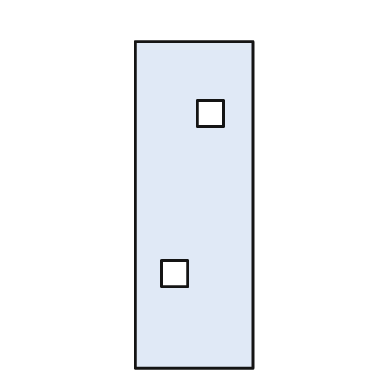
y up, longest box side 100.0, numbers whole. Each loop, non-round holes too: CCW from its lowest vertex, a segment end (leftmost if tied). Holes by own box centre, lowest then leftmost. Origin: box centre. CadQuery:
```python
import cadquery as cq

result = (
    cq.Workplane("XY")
    .moveTo(-18.0, -50.0)
    .lineTo(18.0, -50.0)
    .lineTo(18.0, 50.0)
    .lineTo(-18.0, 50.0)
    .close()
    .moveTo(-10.0, -25.0)
    .lineTo(-2.0, -25.0)
    .lineTo(-2.0, -17.0)
    .lineTo(-10.0, -17.0)
    .close()
    .moveTo(1.0, 24.0)
    .lineTo(9.0, 24.0)
    .lineTo(9.0, 32.0)
    .lineTo(1.0, 32.0)
    .close()
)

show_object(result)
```